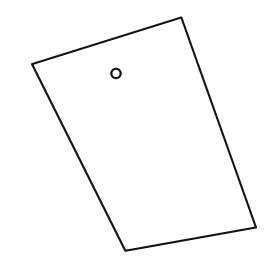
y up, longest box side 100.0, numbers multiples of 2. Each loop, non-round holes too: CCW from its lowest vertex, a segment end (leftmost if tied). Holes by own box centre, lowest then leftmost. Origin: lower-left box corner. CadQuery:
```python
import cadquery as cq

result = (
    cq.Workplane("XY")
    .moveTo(40.0, 0.0)
    .lineTo(96.0, 10.0)
    .lineTo(64.0, 100.0)
    .lineTo(0.0, 80.0)
    .close()
    .moveTo(36.0, 76.0)
    .circle(2.0)
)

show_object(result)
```